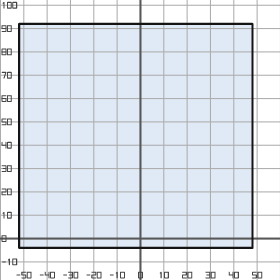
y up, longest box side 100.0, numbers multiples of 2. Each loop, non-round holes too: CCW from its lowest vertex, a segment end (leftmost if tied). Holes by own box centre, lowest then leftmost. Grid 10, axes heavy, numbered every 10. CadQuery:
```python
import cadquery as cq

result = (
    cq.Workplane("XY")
    .moveTo(-52.0, -4.0)
    .lineTo(48.0, -4.0)
    .lineTo(48.0, 92.0)
    .lineTo(-52.0, 92.0)
    .close()
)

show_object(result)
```